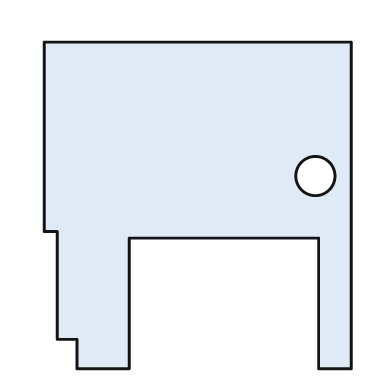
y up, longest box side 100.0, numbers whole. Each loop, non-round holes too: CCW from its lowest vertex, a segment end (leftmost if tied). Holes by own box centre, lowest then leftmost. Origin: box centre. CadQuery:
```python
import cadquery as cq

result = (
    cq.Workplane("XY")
    .moveTo(-37.0, -50.0)
    .lineTo(-21.0, -50.0)
    .lineTo(-21.0, -10.0)
    .lineTo(37.0, -10.0)
    .lineTo(37.0, -50.0)
    .lineTo(47.0, -50.0)
    .lineTo(47.0, 50.0)
    .lineTo(-47.0, 50.0)
    .lineTo(-47.0, -8.0)
    .lineTo(-43.0, -8.0)
    .lineTo(-43.0, -41.0)
    .lineTo(-37.0, -41.0)
    .close()
    .moveTo(36.0, 9.0)
    .circle(6.0)
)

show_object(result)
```